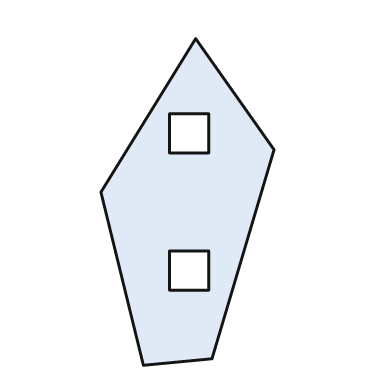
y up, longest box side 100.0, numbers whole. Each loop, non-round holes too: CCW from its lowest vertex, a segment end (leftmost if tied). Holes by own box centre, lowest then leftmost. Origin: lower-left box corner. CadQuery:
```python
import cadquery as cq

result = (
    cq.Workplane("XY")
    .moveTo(13.0, 0.0)
    .lineTo(34.0, 2.0)
    .lineTo(53.0, 66.0)
    .lineTo(29.0, 100.0)
    .lineTo(0.0, 53.0)
    .close()
    .moveTo(21.0, 23.0)
    .lineTo(33.0, 23.0)
    .lineTo(33.0, 35.0)
    .lineTo(21.0, 35.0)
    .close()
    .moveTo(21.0, 65.0)
    .lineTo(33.0, 65.0)
    .lineTo(33.0, 77.0)
    .lineTo(21.0, 77.0)
    .close()
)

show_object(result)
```